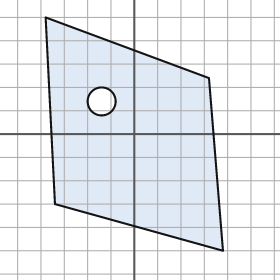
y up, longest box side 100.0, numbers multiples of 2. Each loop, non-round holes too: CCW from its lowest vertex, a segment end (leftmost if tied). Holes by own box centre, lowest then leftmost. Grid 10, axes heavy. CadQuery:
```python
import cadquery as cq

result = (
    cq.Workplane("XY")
    .moveTo(38.0, -50.0)
    .lineTo(32.0, 24.0)
    .lineTo(-38.0, 50.0)
    .lineTo(-34.0, -30.0)
    .close()
    .moveTo(-14.0, 14.0)
    .circle(6.0)
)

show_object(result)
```